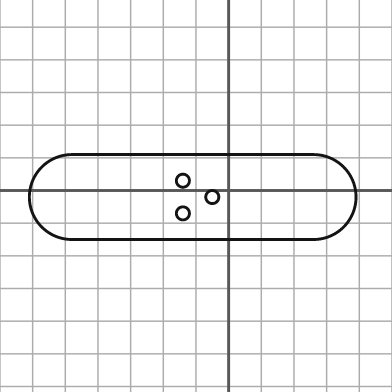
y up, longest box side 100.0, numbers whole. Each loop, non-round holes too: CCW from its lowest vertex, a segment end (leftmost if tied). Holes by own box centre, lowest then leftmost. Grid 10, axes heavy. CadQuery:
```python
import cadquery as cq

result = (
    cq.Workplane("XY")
    .moveTo(-48.0, -15.0)
    .lineTo(26.0, -15.0)
    .threePointArc((39.0, -2.0), (26.0, 11.0))
    .lineTo(-48.0, 11.0)
    .threePointArc((-61.0, -2.0), (-48.0, -15.0))
    .close()
    .moveTo(-14.0, -7.0)
    .circle(2.0)
    .moveTo(-5.0, -2.0)
    .circle(2.0)
    .moveTo(-14.0, 3.0)
    .circle(2.0)
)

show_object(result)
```